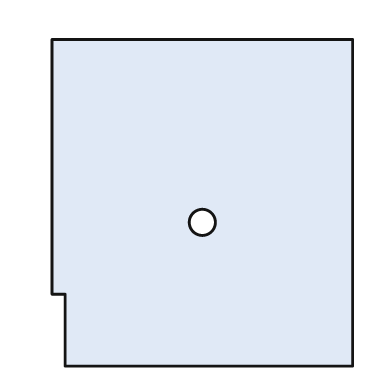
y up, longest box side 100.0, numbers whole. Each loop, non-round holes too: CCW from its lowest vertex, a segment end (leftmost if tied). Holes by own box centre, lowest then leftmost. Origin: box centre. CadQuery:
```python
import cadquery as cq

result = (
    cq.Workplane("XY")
    .moveTo(-42.0, -50.0)
    .lineTo(46.0, -50.0)
    .lineTo(46.0, 50.0)
    .lineTo(-46.0, 50.0)
    .lineTo(-46.0, -28.0)
    .lineTo(-42.0, -28.0)
    .close()
    .moveTo(0.0, -6.0)
    .circle(4.0)
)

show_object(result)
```